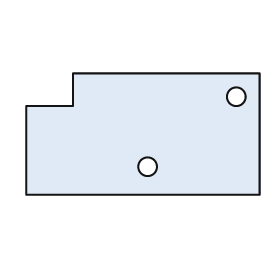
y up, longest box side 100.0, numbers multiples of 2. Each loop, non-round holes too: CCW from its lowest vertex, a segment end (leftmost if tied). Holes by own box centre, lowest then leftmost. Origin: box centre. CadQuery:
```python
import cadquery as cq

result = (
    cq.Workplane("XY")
    .moveTo(-50.0, -26.0)
    .lineTo(50.0, -26.0)
    .lineTo(50.0, 26.0)
    .lineTo(-30.0, 26.0)
    .lineTo(-30.0, 12.0)
    .lineTo(-50.0, 12.0)
    .close()
    .moveTo(2.0, -14.0)
    .circle(4.0)
    .moveTo(40.0, 16.0)
    .circle(4.0)
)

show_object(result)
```